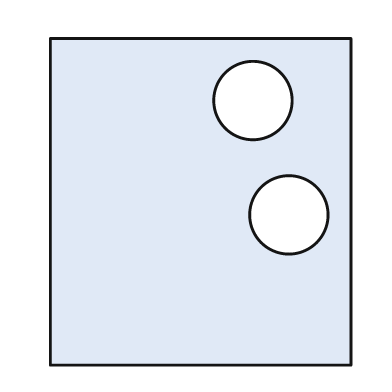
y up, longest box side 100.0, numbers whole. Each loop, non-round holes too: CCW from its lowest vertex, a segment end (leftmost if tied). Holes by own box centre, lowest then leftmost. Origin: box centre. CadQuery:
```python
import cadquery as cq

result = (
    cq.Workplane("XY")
    .moveTo(-46.0, -50.0)
    .lineTo(46.0, -50.0)
    .lineTo(46.0, 50.0)
    .lineTo(-46.0, 50.0)
    .close()
    .moveTo(27.0, -4.0)
    .circle(12.0)
    .moveTo(16.0, 31.0)
    .circle(12.0)
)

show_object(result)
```